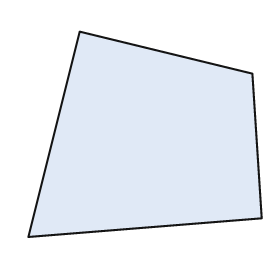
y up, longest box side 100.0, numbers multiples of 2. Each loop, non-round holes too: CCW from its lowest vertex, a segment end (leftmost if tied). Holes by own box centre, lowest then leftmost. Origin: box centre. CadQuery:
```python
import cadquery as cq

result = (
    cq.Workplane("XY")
    .moveTo(-50.0, -44.0)
    .lineTo(50.0, -36.0)
    .lineTo(46.0, 26.0)
    .lineTo(-28.0, 44.0)
    .close()
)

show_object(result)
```